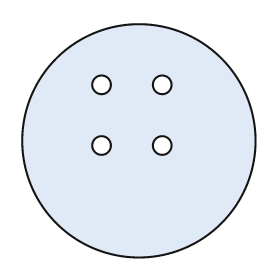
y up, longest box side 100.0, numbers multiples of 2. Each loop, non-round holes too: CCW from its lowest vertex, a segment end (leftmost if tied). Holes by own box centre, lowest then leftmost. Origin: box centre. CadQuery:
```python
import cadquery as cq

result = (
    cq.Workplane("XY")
    .moveTo(0.0, 0.0)
    .circle(50.0)
    .moveTo(-16.0, -2.0)
    .circle(4.0)
    .moveTo(10.0, -2.0)
    .circle(4.0)
    .moveTo(-16.0, 24.0)
    .circle(4.0)
    .moveTo(10.0, 24.0)
    .circle(4.0)
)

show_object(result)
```